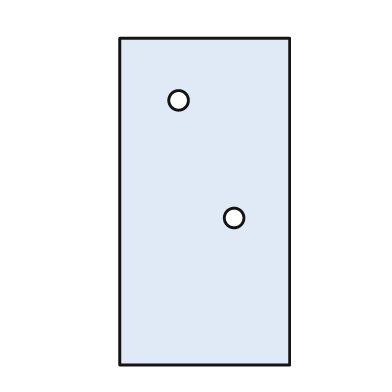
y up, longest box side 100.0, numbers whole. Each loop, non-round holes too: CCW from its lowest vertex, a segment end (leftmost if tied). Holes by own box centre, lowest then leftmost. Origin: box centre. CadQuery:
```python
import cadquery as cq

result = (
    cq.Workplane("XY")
    .moveTo(-26.0, -50.0)
    .lineTo(26.0, -50.0)
    .lineTo(26.0, 50.0)
    .lineTo(-26.0, 50.0)
    .close()
    .moveTo(9.0, -5.0)
    .circle(3.0)
    .moveTo(-8.0, 31.0)
    .circle(3.0)
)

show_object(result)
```